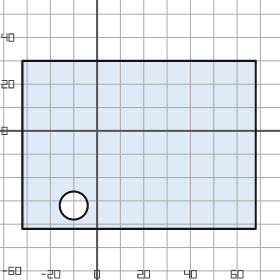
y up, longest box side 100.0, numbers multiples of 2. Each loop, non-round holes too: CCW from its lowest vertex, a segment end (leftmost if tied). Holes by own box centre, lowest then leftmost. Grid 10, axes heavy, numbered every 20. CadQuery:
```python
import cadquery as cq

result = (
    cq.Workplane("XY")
    .moveTo(-32.0, -42.0)
    .lineTo(68.0, -42.0)
    .lineTo(68.0, 30.0)
    .lineTo(-32.0, 30.0)
    .close()
    .moveTo(-10.0, -32.0)
    .circle(6.0)
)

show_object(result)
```